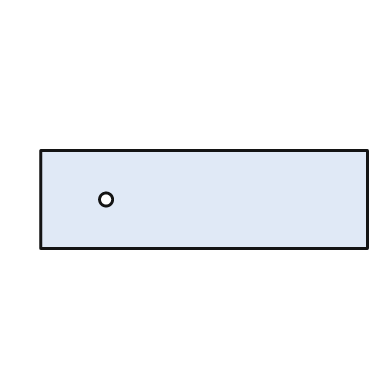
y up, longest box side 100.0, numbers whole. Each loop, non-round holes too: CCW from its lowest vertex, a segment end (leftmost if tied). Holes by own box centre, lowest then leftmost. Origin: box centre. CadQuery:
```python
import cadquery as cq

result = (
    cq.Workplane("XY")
    .moveTo(-50.0, -15.0)
    .lineTo(50.0, -15.0)
    .lineTo(50.0, 15.0)
    .lineTo(-50.0, 15.0)
    .close()
    .moveTo(-30.0, 0.0)
    .circle(2.0)
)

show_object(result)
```